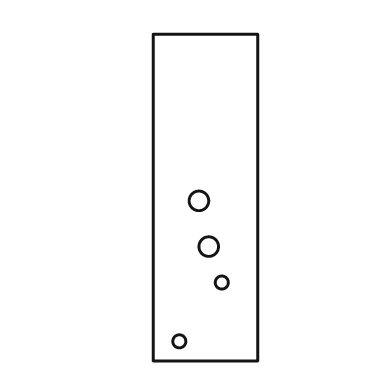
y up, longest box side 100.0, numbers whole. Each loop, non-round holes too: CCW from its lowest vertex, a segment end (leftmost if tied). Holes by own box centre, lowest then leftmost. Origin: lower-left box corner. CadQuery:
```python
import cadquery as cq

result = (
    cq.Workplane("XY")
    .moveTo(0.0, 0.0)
    .lineTo(32.0, 0.0)
    .lineTo(32.0, 100.0)
    .lineTo(0.0, 100.0)
    .close()
    .moveTo(8.0, 6.0)
    .circle(2.0)
    .moveTo(21.0, 24.0)
    .circle(2.0)
    .moveTo(17.0, 35.0)
    .circle(3.0)
    .moveTo(14.0, 49.0)
    .circle(3.0)
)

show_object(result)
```